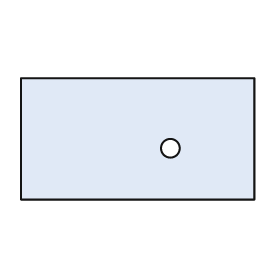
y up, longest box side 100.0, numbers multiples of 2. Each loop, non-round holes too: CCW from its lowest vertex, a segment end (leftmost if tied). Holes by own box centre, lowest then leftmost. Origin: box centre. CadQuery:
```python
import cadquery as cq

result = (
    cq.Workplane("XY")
    .moveTo(-50.0, -26.0)
    .lineTo(50.0, -26.0)
    .lineTo(50.0, 26.0)
    .lineTo(-50.0, 26.0)
    .close()
    .moveTo(14.0, -4.0)
    .circle(4.0)
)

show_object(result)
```